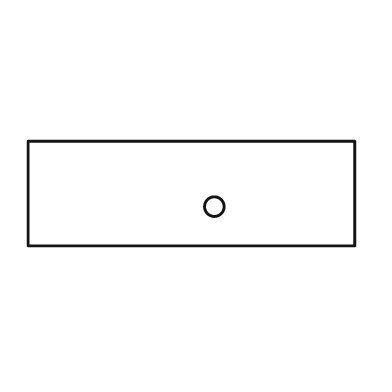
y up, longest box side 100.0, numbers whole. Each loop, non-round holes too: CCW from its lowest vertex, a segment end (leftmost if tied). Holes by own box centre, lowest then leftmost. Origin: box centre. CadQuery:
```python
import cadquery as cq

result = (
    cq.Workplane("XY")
    .moveTo(-50.0, -16.0)
    .lineTo(50.0, -16.0)
    .lineTo(50.0, 16.0)
    .lineTo(-50.0, 16.0)
    .close()
    .moveTo(7.0, -4.0)
    .circle(3.0)
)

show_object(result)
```